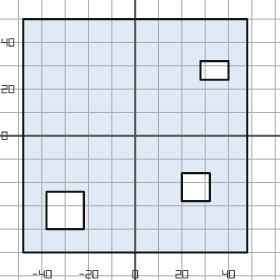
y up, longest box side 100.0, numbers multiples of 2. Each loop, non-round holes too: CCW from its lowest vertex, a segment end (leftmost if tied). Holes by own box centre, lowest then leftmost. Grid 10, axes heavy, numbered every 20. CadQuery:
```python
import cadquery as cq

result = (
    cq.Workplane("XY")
    .moveTo(-48.0, -50.0)
    .lineTo(48.0, -50.0)
    .lineTo(48.0, 50.0)
    .lineTo(-48.0, 50.0)
    .close()
    .moveTo(-38.0, -40.0)
    .lineTo(-22.0, -40.0)
    .lineTo(-22.0, -24.0)
    .lineTo(-38.0, -24.0)
    .close()
    .moveTo(20.0, -28.0)
    .lineTo(32.0, -28.0)
    .lineTo(32.0, -16.0)
    .lineTo(20.0, -16.0)
    .close()
    .moveTo(28.0, 24.0)
    .lineTo(40.0, 24.0)
    .lineTo(40.0, 32.0)
    .lineTo(28.0, 32.0)
    .close()
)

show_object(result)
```